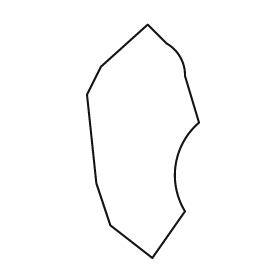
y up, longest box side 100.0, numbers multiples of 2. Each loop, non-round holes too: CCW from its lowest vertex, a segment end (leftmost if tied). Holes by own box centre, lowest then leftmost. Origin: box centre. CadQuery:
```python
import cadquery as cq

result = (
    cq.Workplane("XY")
    .moveTo(4.0, -50.0)
    .lineTo(18.0, -30.0)
    .threePointArc((14.0, -10.0), (24.0, 8.0))
    .lineTo(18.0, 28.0)
    .threePointArc((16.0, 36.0), (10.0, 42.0))
    .lineTo(2.0, 50.0)
    .lineTo(-18.0, 32.0)
    .lineTo(-24.0, 20.0)
    .lineTo(-20.0, -18.0)
    .lineTo(-14.0, -36.0)
    .close()
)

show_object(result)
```